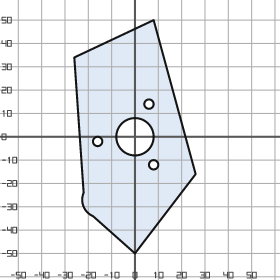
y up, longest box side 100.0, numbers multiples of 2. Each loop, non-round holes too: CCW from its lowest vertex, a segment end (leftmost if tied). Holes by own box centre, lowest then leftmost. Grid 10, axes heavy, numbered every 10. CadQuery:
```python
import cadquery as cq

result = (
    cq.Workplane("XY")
    .moveTo(0.0, -50.0)
    .lineTo(26.0, -16.0)
    .lineTo(8.0, 50.0)
    .lineTo(-26.0, 34.0)
    .lineTo(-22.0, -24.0)
    .threePointArc((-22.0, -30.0), (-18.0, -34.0))
    .close()
    .moveTo(8.0, -12.0)
    .circle(2.0)
    .moveTo(-16.0, -2.0)
    .circle(2.0)
    .moveTo(0.0, 0.0)
    .circle(8.0)
    .moveTo(6.0, 14.0)
    .circle(2.0)
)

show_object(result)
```